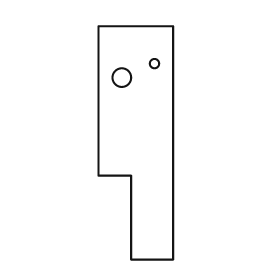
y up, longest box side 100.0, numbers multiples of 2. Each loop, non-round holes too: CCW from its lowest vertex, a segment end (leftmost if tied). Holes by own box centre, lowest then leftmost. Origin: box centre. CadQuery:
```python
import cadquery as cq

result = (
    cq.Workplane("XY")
    .moveTo(-2.0, -50.0)
    .lineTo(16.0, -50.0)
    .lineTo(16.0, 50.0)
    .lineTo(-16.0, 50.0)
    .lineTo(-16.0, -14.0)
    .lineTo(-2.0, -14.0)
    .close()
    .moveTo(-6.0, 28.0)
    .circle(4.0)
    .moveTo(8.0, 34.0)
    .circle(2.0)
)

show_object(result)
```